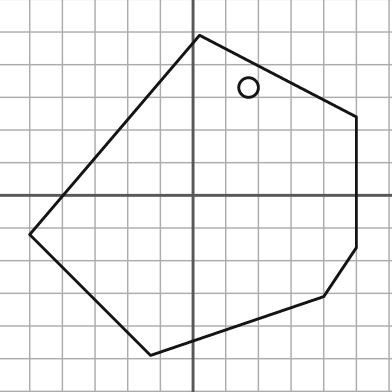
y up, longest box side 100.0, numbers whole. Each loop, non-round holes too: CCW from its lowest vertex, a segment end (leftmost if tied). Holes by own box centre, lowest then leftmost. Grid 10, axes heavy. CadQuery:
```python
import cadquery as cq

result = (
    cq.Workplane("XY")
    .moveTo(-13.0, -49.0)
    .lineTo(40.0, -31.0)
    .lineTo(50.0, -16.0)
    .lineTo(50.0, 24.0)
    .lineTo(2.0, 49.0)
    .lineTo(-50.0, -12.0)
    .close()
    .moveTo(17.0, 33.0)
    .circle(3.0)
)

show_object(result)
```